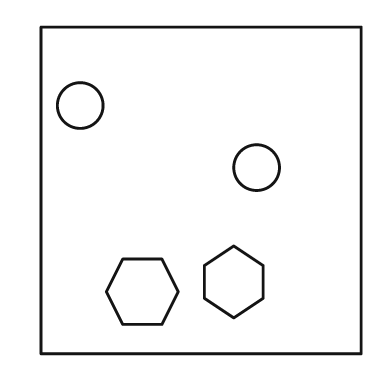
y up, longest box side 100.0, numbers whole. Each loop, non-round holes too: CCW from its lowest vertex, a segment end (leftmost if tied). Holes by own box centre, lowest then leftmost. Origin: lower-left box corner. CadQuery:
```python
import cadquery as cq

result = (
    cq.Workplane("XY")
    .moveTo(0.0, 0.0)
    .lineTo(98.0, 0.0)
    .lineTo(98.0, 100.0)
    .lineTo(0.0, 100.0)
    .close()
    .moveTo(25.0, 9.0)
    .lineTo(37.0, 9.0)
    .lineTo(42.0, 19.0)
    .lineTo(37.0, 29.0)
    .lineTo(25.0, 29.0)
    .lineTo(20.0, 19.0)
    .close()
    .moveTo(59.0, 11.0)
    .lineTo(68.0, 17.0)
    .lineTo(68.0, 27.0)
    .lineTo(59.0, 33.0)
    .lineTo(50.0, 27.0)
    .lineTo(50.0, 17.0)
    .close()
    .moveTo(66.0, 57.0)
    .circle(7.0)
    .moveTo(12.0, 76.0)
    .circle(7.0)
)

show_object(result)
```